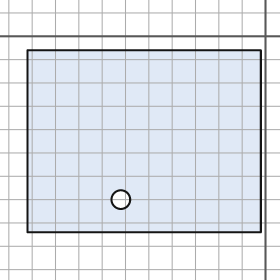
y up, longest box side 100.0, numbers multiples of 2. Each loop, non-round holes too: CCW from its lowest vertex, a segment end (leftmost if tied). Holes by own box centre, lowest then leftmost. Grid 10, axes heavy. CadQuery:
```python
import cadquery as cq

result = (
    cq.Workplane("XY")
    .moveTo(-102.0, -84.0)
    .lineTo(-2.0, -84.0)
    .lineTo(-2.0, -6.0)
    .lineTo(-102.0, -6.0)
    .close()
    .moveTo(-62.0, -70.0)
    .circle(4.0)
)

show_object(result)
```